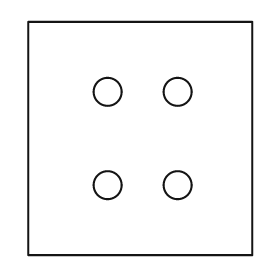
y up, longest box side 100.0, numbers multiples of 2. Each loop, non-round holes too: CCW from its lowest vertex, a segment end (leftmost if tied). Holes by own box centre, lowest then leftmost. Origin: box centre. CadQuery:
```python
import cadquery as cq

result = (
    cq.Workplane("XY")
    .moveTo(-48.0, -50.0)
    .lineTo(48.0, -50.0)
    .lineTo(48.0, 50.0)
    .lineTo(-48.0, 50.0)
    .close()
    .moveTo(-14.0, -20.0)
    .circle(6.0)
    .moveTo(16.0, -20.0)
    .circle(6.0)
    .moveTo(-14.0, 20.0)
    .circle(6.0)
    .moveTo(16.0, 20.0)
    .circle(6.0)
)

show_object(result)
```